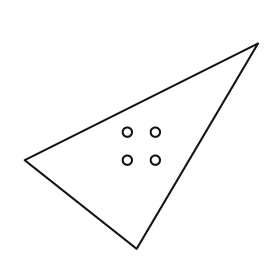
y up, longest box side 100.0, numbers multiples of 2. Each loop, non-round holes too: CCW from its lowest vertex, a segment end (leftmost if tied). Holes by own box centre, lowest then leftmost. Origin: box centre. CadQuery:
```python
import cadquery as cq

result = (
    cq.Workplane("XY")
    .moveTo(-2.0, -44.0)
    .lineTo(50.0, 44.0)
    .lineTo(-50.0, -6.0)
    .close()
    .moveTo(-6.0, -6.0)
    .circle(2.0)
    .moveTo(6.0, -6.0)
    .circle(2.0)
    .moveTo(-6.0, 6.0)
    .circle(2.0)
    .moveTo(6.0, 6.0)
    .circle(2.0)
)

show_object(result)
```